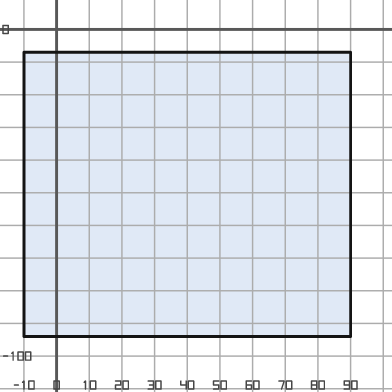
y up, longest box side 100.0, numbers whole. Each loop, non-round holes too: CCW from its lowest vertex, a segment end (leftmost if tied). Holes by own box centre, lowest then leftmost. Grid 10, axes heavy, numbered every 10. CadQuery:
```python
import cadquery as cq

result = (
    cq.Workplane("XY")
    .moveTo(-10.0, -94.0)
    .lineTo(90.0, -94.0)
    .lineTo(90.0, -7.0)
    .lineTo(-10.0, -7.0)
    .close()
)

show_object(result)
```